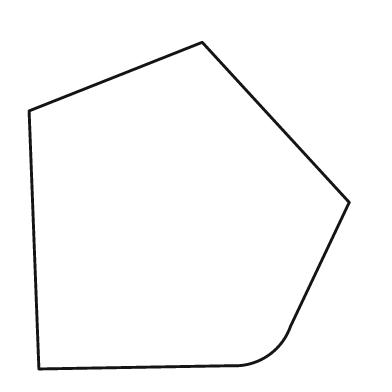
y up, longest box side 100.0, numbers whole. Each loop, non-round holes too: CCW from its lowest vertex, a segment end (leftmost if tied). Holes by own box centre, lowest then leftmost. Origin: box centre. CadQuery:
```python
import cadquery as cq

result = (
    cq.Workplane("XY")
    .moveTo(-46.0, -50.0)
    .lineTo(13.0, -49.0)
    .threePointArc((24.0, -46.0), (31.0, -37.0))
    .lineTo(49.0, 1.0)
    .lineTo(4.0, 50.0)
    .lineTo(-49.0, 29.0)
    .close()
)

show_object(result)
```